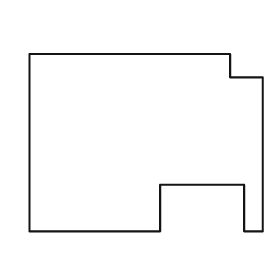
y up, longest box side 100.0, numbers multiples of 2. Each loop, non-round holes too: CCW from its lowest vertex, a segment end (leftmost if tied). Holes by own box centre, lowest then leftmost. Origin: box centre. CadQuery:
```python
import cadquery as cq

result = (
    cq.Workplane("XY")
    .moveTo(-50.0, -38.0)
    .lineTo(6.0, -38.0)
    .lineTo(6.0, -18.0)
    .lineTo(42.0, -18.0)
    .lineTo(42.0, -38.0)
    .lineTo(50.0, -38.0)
    .lineTo(50.0, 28.0)
    .lineTo(36.0, 28.0)
    .lineTo(36.0, 38.0)
    .lineTo(-50.0, 38.0)
    .close()
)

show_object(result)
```